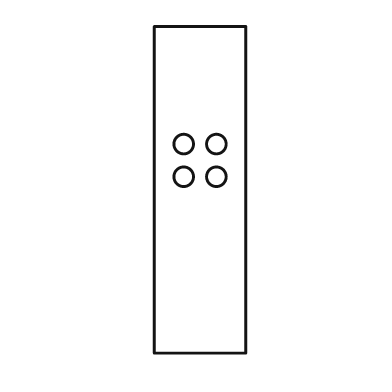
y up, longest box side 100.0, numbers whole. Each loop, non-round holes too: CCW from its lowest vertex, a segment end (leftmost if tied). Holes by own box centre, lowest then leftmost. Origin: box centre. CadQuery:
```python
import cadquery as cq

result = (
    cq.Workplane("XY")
    .moveTo(-14.0, -50.0)
    .lineTo(14.0, -50.0)
    .lineTo(14.0, 50.0)
    .lineTo(-14.0, 50.0)
    .close()
    .moveTo(-5.0, 4.0)
    .circle(3.0)
    .moveTo(5.0, 4.0)
    .circle(3.0)
    .moveTo(-5.0, 14.0)
    .circle(3.0)
    .moveTo(5.0, 14.0)
    .circle(3.0)
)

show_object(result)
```